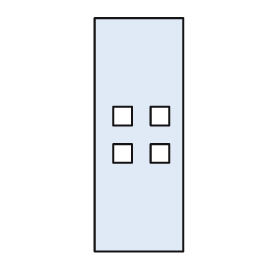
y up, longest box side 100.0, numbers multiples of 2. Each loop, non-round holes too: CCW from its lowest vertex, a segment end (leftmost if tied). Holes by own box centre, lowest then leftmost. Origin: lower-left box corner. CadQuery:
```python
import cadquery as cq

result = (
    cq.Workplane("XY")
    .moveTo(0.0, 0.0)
    .lineTo(38.0, 0.0)
    .lineTo(38.0, 100.0)
    .lineTo(0.0, 100.0)
    .close()
    .moveTo(8.0, 38.0)
    .lineTo(16.0, 38.0)
    .lineTo(16.0, 46.0)
    .lineTo(8.0, 46.0)
    .close()
    .moveTo(24.0, 38.0)
    .lineTo(32.0, 38.0)
    .lineTo(32.0, 46.0)
    .lineTo(24.0, 46.0)
    .close()
    .moveTo(8.0, 54.0)
    .lineTo(16.0, 54.0)
    .lineTo(16.0, 62.0)
    .lineTo(8.0, 62.0)
    .close()
    .moveTo(24.0, 54.0)
    .lineTo(32.0, 54.0)
    .lineTo(32.0, 62.0)
    .lineTo(24.0, 62.0)
    .close()
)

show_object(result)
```